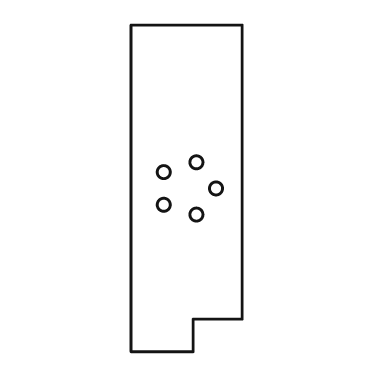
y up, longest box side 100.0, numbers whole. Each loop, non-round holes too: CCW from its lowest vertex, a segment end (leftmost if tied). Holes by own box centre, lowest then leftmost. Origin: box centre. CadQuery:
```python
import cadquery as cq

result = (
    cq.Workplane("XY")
    .moveTo(-17.0, -50.0)
    .lineTo(2.0, -50.0)
    .lineTo(2.0, -40.0)
    .lineTo(17.0, -40.0)
    .lineTo(17.0, 50.0)
    .lineTo(-17.0, 50.0)
    .close()
    .moveTo(3.0, -8.0)
    .circle(2.0)
    .moveTo(-7.0, -5.0)
    .circle(2.0)
    .moveTo(9.0, 0.0)
    .circle(2.0)
    .moveTo(-7.0, 5.0)
    .circle(2.0)
    .moveTo(3.0, 8.0)
    .circle(2.0)
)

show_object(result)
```